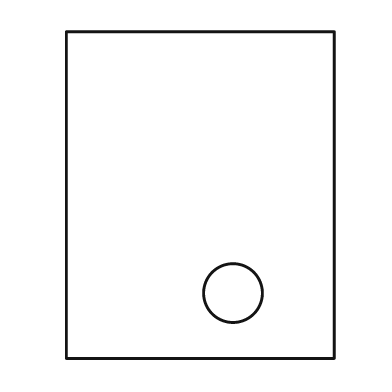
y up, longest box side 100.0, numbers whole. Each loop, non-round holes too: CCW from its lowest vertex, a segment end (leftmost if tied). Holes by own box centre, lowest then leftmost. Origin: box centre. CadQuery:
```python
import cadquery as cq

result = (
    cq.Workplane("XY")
    .moveTo(-41.0, -50.0)
    .lineTo(41.0, -50.0)
    .lineTo(41.0, 50.0)
    .lineTo(-41.0, 50.0)
    .close()
    .moveTo(10.0, -30.0)
    .circle(9.0)
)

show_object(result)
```